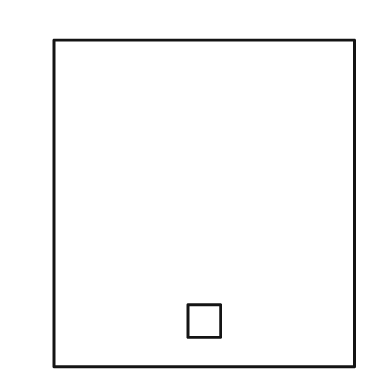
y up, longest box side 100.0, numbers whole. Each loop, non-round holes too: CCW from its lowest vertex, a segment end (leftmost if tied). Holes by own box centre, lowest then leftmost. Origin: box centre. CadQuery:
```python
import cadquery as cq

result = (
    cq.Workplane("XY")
    .moveTo(-46.0, -50.0)
    .lineTo(46.0, -50.0)
    .lineTo(46.0, 50.0)
    .lineTo(-46.0, 50.0)
    .close()
    .moveTo(-5.0, -41.0)
    .lineTo(5.0, -41.0)
    .lineTo(5.0, -31.0)
    .lineTo(-5.0, -31.0)
    .close()
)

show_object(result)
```